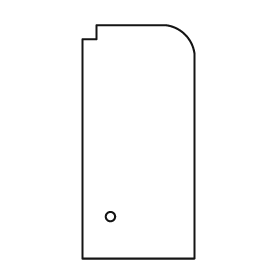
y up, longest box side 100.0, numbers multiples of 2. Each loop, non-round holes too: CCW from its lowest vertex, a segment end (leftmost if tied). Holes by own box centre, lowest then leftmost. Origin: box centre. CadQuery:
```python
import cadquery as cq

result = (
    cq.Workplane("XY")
    .moveTo(-24.0, -50.0)
    .lineTo(24.0, -50.0)
    .lineTo(24.0, 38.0)
    .threePointArc((20.0, 46.0), (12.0, 50.0))
    .lineTo(-18.0, 50.0)
    .lineTo(-18.0, 44.0)
    .lineTo(-24.0, 44.0)
    .close()
    .moveTo(-12.0, -32.0)
    .circle(2.0)
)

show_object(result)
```